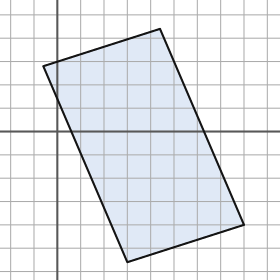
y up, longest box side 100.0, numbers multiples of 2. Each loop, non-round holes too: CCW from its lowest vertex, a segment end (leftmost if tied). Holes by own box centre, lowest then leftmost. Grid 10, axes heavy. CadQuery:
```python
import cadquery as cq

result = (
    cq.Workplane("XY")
    .moveTo(30.0, -56.0)
    .lineTo(80.0, -40.0)
    .lineTo(44.0, 44.0)
    .lineTo(-6.0, 28.0)
    .close()
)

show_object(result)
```